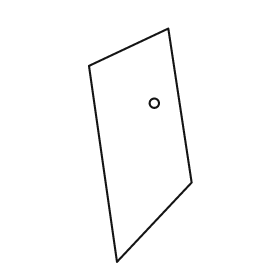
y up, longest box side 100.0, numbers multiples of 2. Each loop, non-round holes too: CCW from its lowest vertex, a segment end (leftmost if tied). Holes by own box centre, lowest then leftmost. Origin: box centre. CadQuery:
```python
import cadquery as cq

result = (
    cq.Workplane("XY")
    .moveTo(-10.0, -50.0)
    .lineTo(22.0, -16.0)
    .lineTo(12.0, 50.0)
    .lineTo(-22.0, 34.0)
    .close()
    .moveTo(6.0, 18.0)
    .circle(2.0)
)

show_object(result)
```